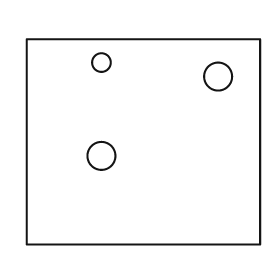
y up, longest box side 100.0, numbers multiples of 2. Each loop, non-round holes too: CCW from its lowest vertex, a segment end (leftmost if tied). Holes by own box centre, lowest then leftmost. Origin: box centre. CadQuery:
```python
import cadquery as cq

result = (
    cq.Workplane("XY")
    .moveTo(-50.0, -44.0)
    .lineTo(50.0, -44.0)
    .lineTo(50.0, 44.0)
    .lineTo(-50.0, 44.0)
    .close()
    .moveTo(-18.0, -6.0)
    .circle(6.0)
    .moveTo(32.0, 28.0)
    .circle(6.0)
    .moveTo(-18.0, 34.0)
    .circle(4.0)
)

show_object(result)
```